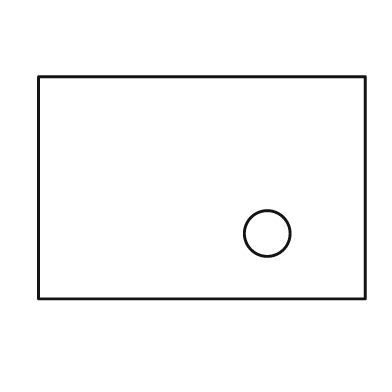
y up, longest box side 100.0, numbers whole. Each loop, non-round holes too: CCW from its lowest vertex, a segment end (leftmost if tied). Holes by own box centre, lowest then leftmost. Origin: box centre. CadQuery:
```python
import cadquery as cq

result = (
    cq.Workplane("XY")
    .moveTo(-50.0, -34.0)
    .lineTo(50.0, -34.0)
    .lineTo(50.0, 34.0)
    .lineTo(-50.0, 34.0)
    .close()
    .moveTo(20.0, -14.0)
    .circle(7.0)
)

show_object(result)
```